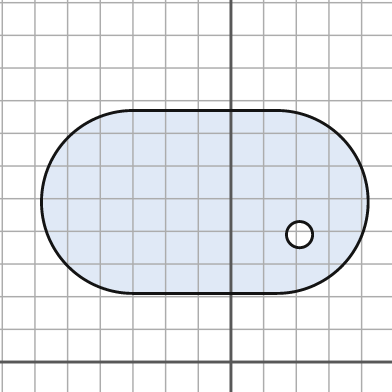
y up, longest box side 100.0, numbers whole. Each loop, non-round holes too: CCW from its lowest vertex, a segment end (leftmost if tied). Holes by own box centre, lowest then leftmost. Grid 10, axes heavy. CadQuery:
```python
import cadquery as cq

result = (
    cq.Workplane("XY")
    .moveTo(-30.0, 21.0)
    .lineTo(14.0, 21.0)
    .threePointArc((42.0, 49.0), (14.0, 77.0))
    .lineTo(-30.0, 77.0)
    .threePointArc((-58.0, 49.0), (-30.0, 21.0))
    .close()
    .moveTo(21.0, 39.0)
    .circle(4.0)
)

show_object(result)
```